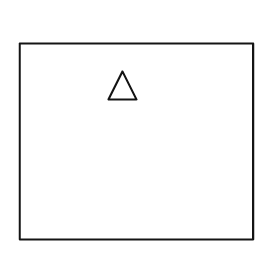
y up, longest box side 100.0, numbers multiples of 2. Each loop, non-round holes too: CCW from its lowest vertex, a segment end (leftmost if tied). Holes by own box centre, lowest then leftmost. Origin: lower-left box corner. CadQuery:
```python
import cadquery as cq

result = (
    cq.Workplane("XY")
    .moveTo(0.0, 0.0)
    .lineTo(100.0, 0.0)
    .lineTo(100.0, 84.0)
    .lineTo(0.0, 84.0)
    .close()
    .moveTo(38.0, 60.0)
    .lineTo(50.0, 60.0)
    .lineTo(44.0, 72.0)
    .close()
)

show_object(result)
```